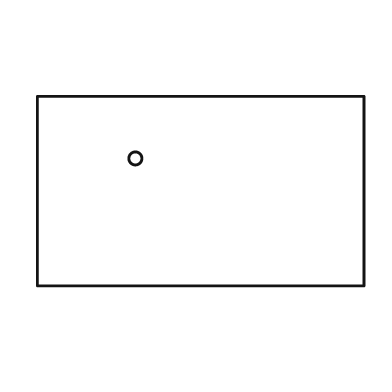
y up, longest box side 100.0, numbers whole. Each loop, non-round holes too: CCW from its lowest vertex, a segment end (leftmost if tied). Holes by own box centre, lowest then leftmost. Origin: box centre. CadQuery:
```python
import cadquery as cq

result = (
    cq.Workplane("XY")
    .moveTo(-50.0, -29.0)
    .lineTo(50.0, -29.0)
    .lineTo(50.0, 29.0)
    .lineTo(-50.0, 29.0)
    .close()
    .moveTo(-20.0, 10.0)
    .circle(2.0)
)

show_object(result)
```